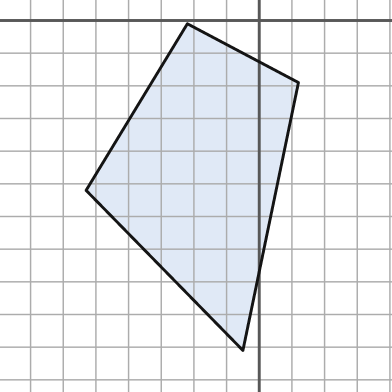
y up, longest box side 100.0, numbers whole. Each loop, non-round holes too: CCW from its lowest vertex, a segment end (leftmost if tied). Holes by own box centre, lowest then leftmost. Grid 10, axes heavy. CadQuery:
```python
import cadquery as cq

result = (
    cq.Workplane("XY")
    .moveTo(-5.0, -101.0)
    .lineTo(12.0, -19.0)
    .lineTo(-22.0, -1.0)
    .lineTo(-53.0, -52.0)
    .close()
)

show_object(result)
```